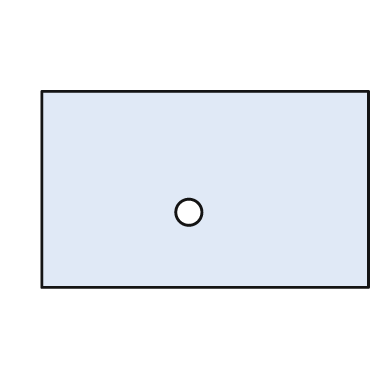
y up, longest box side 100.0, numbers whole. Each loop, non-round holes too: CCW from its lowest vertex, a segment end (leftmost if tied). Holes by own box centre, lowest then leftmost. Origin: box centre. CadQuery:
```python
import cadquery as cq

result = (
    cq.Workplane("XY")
    .moveTo(-50.0, -30.0)
    .lineTo(50.0, -30.0)
    .lineTo(50.0, 30.0)
    .lineTo(-50.0, 30.0)
    .close()
    .moveTo(-5.0, -7.0)
    .circle(4.0)
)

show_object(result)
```